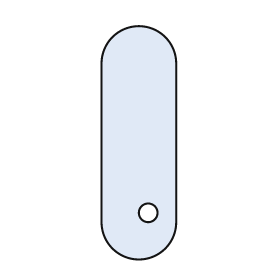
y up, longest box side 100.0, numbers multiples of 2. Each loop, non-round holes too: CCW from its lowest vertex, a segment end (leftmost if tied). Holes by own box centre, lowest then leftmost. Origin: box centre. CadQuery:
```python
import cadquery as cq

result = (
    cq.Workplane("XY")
    .moveTo(-16.0, -34.0)
    .threePointArc((0.0, -50.0), (16.0, -34.0))
    .lineTo(16.0, 34.0)
    .threePointArc((0.0, 50.0), (-16.0, 34.0))
    .close()
    .moveTo(4.0, -30.0)
    .circle(4.0)
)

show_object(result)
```